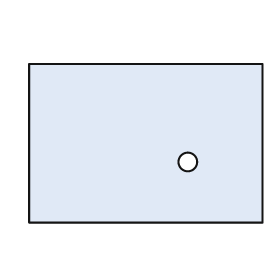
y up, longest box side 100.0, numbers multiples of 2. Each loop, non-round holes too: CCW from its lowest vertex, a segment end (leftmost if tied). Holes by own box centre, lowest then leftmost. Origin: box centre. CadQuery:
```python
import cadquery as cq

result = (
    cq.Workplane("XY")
    .moveTo(-50.0, -34.0)
    .lineTo(50.0, -34.0)
    .lineTo(50.0, 34.0)
    .lineTo(-50.0, 34.0)
    .close()
    .moveTo(18.0, -8.0)
    .circle(4.0)
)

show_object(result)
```